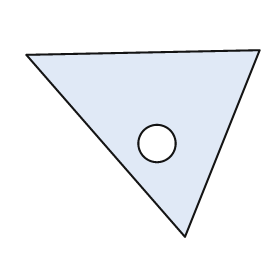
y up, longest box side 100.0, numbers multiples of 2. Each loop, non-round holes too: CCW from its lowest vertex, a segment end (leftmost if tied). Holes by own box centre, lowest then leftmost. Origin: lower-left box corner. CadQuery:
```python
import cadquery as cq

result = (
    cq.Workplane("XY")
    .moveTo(68.0, 0.0)
    .lineTo(100.0, 80.0)
    .lineTo(0.0, 78.0)
    .close()
    .moveTo(56.0, 40.0)
    .circle(8.0)
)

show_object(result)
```